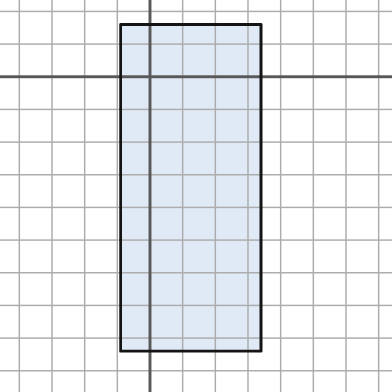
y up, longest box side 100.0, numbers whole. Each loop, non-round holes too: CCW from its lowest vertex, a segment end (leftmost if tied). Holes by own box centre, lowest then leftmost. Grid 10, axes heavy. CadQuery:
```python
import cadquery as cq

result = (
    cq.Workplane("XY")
    .moveTo(-9.0, -84.0)
    .lineTo(34.0, -84.0)
    .lineTo(34.0, 16.0)
    .lineTo(-9.0, 16.0)
    .close()
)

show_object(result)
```